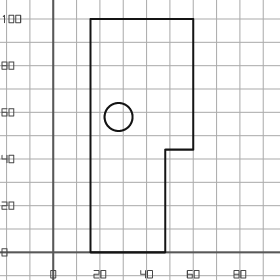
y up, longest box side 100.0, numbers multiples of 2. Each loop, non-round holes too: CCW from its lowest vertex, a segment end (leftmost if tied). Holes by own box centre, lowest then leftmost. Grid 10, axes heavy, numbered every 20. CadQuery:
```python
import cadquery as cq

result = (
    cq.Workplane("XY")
    .moveTo(16.0, 0.0)
    .lineTo(48.0, 0.0)
    .lineTo(48.0, 44.0)
    .lineTo(60.0, 44.0)
    .lineTo(60.0, 100.0)
    .lineTo(16.0, 100.0)
    .close()
    .moveTo(28.0, 58.0)
    .circle(6.0)
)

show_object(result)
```